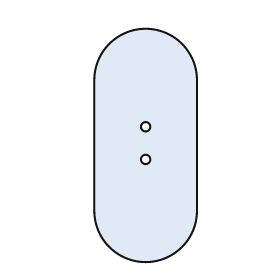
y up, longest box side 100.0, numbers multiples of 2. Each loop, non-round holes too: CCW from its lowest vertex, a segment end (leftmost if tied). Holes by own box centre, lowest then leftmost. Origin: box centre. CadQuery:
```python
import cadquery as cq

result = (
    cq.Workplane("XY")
    .moveTo(-22.0, -28.0)
    .threePointArc((0.0, -50.0), (22.0, -28.0))
    .lineTo(22.0, 28.0)
    .threePointArc((0.0, 50.0), (-22.0, 28.0))
    .close()
    .moveTo(0.0, -6.0)
    .circle(2.0)
    .moveTo(0.0, 8.0)
    .circle(2.0)
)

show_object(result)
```